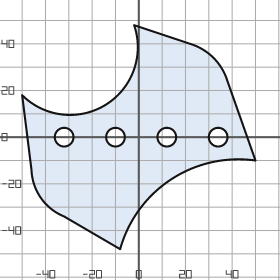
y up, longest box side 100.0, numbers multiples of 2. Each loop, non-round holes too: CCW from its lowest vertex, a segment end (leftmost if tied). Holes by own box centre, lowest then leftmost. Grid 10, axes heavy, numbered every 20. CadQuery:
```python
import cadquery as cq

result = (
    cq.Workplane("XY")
    .moveTo(-8.0, -48.0)
    .threePointArc((14.0, -18.0), (50.0, -10.0))
    .lineTo(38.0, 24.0)
    .threePointArc((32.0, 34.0), (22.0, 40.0))
    .lineTo(-2.0, 48.0)
    .threePointArc((-14.0, 14.0), (-50.0, 18.0))
    .lineTo(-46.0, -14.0)
    .threePointArc((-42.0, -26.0), (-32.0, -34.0))
    .close()
    .moveTo(-32.0, 0.0)
    .circle(4.0)
    .moveTo(-10.0, 0.0)
    .circle(4.0)
    .moveTo(12.0, 0.0)
    .circle(4.0)
    .moveTo(34.0, 0.0)
    .circle(4.0)
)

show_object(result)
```